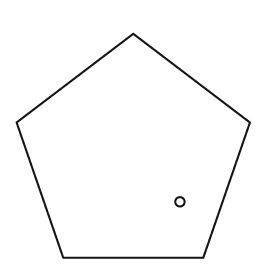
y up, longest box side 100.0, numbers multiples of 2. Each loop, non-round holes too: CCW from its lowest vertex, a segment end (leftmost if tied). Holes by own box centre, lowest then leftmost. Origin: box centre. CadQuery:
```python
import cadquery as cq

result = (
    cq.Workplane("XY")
    .moveTo(-30.0, -48.0)
    .lineTo(30.0, -48.0)
    .lineTo(50.0, 10.0)
    .lineTo(0.0, 48.0)
    .lineTo(-50.0, 10.0)
    .close()
    .moveTo(20.0, -24.0)
    .circle(2.0)
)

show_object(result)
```